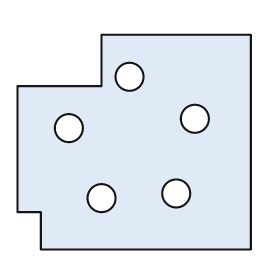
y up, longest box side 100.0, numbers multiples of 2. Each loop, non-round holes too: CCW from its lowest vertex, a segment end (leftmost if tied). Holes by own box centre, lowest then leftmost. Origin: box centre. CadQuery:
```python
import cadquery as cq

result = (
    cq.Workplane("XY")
    .moveTo(-40.0, -46.0)
    .lineTo(50.0, -46.0)
    .lineTo(50.0, 46.0)
    .lineTo(-14.0, 46.0)
    .lineTo(-14.0, 24.0)
    .lineTo(-50.0, 24.0)
    .lineTo(-50.0, -30.0)
    .lineTo(-40.0, -30.0)
    .close()
    .moveTo(-14.0, -24.0)
    .circle(6.0)
    .moveTo(18.0, -22.0)
    .circle(6.0)
    .moveTo(-28.0, 6.0)
    .circle(6.0)
    .moveTo(26.0, 10.0)
    .circle(6.0)
    .moveTo(-2.0, 28.0)
    .circle(6.0)
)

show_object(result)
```